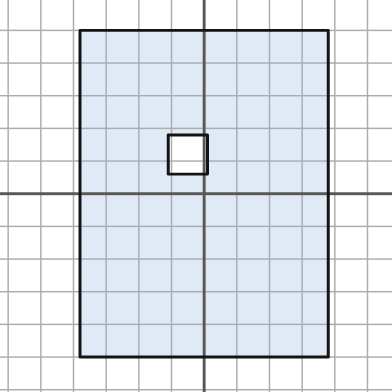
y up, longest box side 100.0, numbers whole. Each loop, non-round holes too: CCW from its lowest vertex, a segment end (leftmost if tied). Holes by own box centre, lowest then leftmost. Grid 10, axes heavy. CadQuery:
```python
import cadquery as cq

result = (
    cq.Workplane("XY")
    .moveTo(-38.0, -50.0)
    .lineTo(38.0, -50.0)
    .lineTo(38.0, 50.0)
    .lineTo(-38.0, 50.0)
    .close()
    .moveTo(-11.0, 6.0)
    .lineTo(1.0, 6.0)
    .lineTo(1.0, 18.0)
    .lineTo(-11.0, 18.0)
    .close()
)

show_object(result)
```